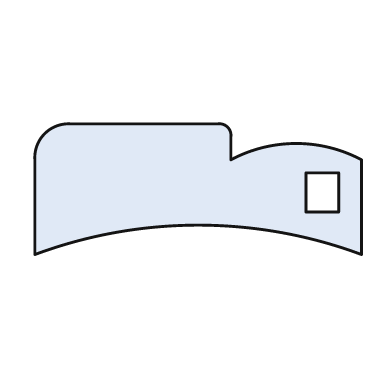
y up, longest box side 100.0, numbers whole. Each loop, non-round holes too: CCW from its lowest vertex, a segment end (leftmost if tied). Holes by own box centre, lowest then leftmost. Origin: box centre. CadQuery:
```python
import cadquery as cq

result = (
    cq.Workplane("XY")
    .moveTo(-50.0, -20.0)
    .threePointArc((0.0, -11.0), (50.0, -20.0))
    .lineTo(50.0, 9.0)
    .threePointArc((30.0, 14.0), (10.0, 9.0))
    .lineTo(10.0, 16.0)
    .threePointArc((9.0, 19.0), (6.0, 20.0))
    .lineTo(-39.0, 20.0)
    .threePointArc((-47.0, 17.0), (-50.0, 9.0))
    .close()
    .moveTo(33.0, -7.0)
    .lineTo(43.0, -7.0)
    .lineTo(43.0, 5.0)
    .lineTo(33.0, 5.0)
    .close()
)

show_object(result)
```